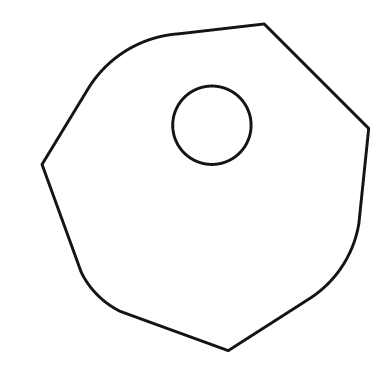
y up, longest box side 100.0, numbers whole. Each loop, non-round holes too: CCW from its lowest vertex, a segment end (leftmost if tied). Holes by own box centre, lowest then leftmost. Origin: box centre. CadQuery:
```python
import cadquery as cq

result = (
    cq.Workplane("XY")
    .moveTo(7.0, -50.0)
    .lineTo(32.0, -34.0)
    .threePointArc((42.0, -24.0), (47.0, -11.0))
    .lineTo(50.0, 18.0)
    .lineTo(18.0, 50.0)
    .lineTo(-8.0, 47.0)
    .threePointArc((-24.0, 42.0), (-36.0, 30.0))
    .lineTo(-50.0, 7.0)
    .lineTo(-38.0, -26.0)
    .threePointArc((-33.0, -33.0), (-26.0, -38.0))
    .close()
    .moveTo(2.0, 19.0)
    .circle(12.0)
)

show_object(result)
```